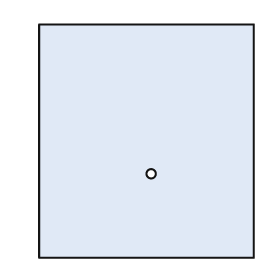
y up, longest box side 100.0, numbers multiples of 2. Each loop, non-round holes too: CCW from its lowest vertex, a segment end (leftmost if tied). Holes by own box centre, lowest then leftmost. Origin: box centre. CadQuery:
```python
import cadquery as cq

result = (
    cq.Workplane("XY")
    .moveTo(-46.0, -50.0)
    .lineTo(46.0, -50.0)
    .lineTo(46.0, 50.0)
    .lineTo(-46.0, 50.0)
    .close()
    .moveTo(2.0, -14.0)
    .circle(2.0)
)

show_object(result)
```